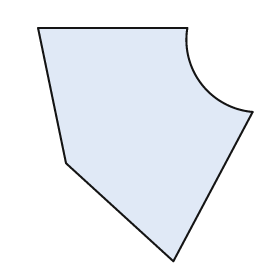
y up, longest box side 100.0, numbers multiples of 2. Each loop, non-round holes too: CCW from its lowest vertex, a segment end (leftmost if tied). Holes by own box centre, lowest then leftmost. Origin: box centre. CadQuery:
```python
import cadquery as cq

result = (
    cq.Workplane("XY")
    .moveTo(12.0, -50.0)
    .lineTo(46.0, 14.0)
    .threePointArc((24.0, 26.0), (18.0, 50.0))
    .lineTo(-46.0, 50.0)
    .lineTo(-34.0, -8.0)
    .close()
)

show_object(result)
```